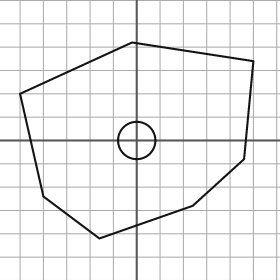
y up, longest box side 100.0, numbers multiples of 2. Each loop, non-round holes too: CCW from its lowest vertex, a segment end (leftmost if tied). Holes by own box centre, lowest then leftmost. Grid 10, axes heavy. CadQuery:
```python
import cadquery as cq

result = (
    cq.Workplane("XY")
    .moveTo(-16.0, -42.0)
    .lineTo(24.0, -28.0)
    .lineTo(46.0, -8.0)
    .lineTo(50.0, 34.0)
    .lineTo(-2.0, 42.0)
    .lineTo(-50.0, 20.0)
    .lineTo(-40.0, -24.0)
    .close()
    .moveTo(0.0, 0.0)
    .circle(8.0)
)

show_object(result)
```